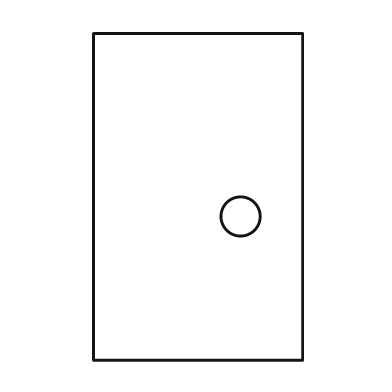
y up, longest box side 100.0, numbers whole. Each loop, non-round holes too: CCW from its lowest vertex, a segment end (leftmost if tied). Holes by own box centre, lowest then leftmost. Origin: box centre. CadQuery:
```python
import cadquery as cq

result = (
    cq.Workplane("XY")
    .moveTo(-32.0, -50.0)
    .lineTo(32.0, -50.0)
    .lineTo(32.0, 50.0)
    .lineTo(-32.0, 50.0)
    .close()
    .moveTo(13.0, -6.0)
    .circle(6.0)
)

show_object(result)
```